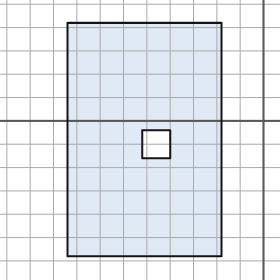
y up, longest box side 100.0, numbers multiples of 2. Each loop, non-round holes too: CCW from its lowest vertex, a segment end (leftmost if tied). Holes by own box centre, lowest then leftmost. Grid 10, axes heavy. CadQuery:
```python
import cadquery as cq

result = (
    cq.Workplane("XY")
    .moveTo(-84.0, -58.0)
    .lineTo(-18.0, -58.0)
    .lineTo(-18.0, 42.0)
    .lineTo(-84.0, 42.0)
    .close()
    .moveTo(-52.0, -16.0)
    .lineTo(-40.0, -16.0)
    .lineTo(-40.0, -4.0)
    .lineTo(-52.0, -4.0)
    .close()
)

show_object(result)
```